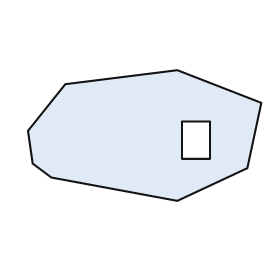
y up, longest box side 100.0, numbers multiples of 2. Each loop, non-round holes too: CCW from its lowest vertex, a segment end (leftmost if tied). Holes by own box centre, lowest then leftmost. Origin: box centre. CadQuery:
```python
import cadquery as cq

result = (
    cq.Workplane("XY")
    .moveTo(14.0, -28.0)
    .lineTo(44.0, -14.0)
    .lineTo(50.0, 14.0)
    .lineTo(14.0, 28.0)
    .lineTo(-34.0, 22.0)
    .lineTo(-50.0, 2.0)
    .lineTo(-48.0, -12.0)
    .lineTo(-40.0, -18.0)
    .close()
    .moveTo(16.0, -10.0)
    .lineTo(28.0, -10.0)
    .lineTo(28.0, 6.0)
    .lineTo(16.0, 6.0)
    .close()
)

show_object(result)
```